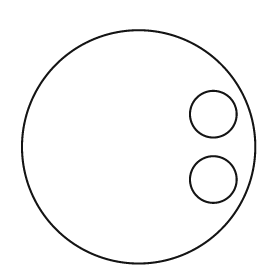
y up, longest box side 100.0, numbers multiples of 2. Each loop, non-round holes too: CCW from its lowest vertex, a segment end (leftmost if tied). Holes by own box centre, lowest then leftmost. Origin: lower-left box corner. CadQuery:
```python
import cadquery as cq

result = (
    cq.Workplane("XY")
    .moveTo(50.0, 50.0)
    .circle(50.0)
    .moveTo(82.0, 36.0)
    .circle(10.0)
    .moveTo(82.0, 64.0)
    .circle(10.0)
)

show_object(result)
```